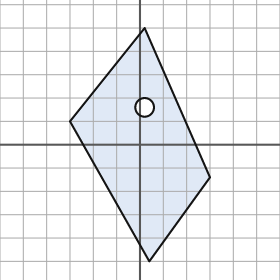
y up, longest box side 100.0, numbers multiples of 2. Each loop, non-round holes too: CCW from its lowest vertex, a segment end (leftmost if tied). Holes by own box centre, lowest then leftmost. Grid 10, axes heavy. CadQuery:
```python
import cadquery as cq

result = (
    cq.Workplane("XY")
    .moveTo(4.0, -50.0)
    .lineTo(30.0, -14.0)
    .lineTo(2.0, 50.0)
    .lineTo(-30.0, 10.0)
    .close()
    .moveTo(2.0, 16.0)
    .circle(4.0)
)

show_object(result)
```